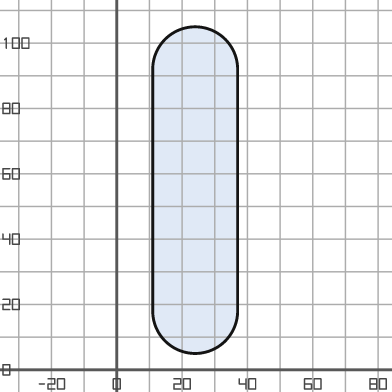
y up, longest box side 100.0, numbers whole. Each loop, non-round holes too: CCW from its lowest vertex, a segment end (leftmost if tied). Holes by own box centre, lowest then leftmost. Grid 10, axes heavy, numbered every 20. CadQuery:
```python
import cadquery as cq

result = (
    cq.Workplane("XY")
    .moveTo(11.0, 18.0)
    .threePointArc((24.0, 5.0), (37.0, 18.0))
    .lineTo(37.0, 92.0)
    .threePointArc((24.0, 105.0), (11.0, 92.0))
    .close()
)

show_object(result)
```